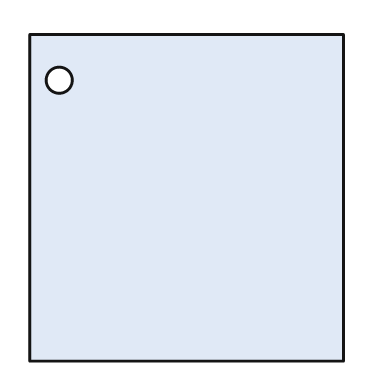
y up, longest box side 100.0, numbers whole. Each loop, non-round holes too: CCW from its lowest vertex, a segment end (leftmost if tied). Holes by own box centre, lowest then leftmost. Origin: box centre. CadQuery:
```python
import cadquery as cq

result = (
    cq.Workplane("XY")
    .moveTo(-48.0, -50.0)
    .lineTo(48.0, -50.0)
    .lineTo(48.0, 50.0)
    .lineTo(-48.0, 50.0)
    .close()
    .moveTo(-39.0, 36.0)
    .circle(4.0)
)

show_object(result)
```